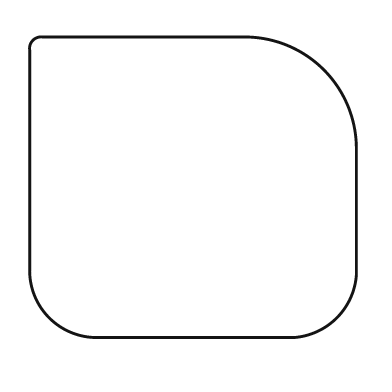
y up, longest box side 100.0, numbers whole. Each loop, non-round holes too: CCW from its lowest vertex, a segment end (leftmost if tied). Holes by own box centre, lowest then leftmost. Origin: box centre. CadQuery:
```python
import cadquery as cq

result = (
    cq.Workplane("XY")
    .moveTo(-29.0, -46.0)
    .lineTo(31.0, -46.0)
    .threePointArc((44.0, -40.0), (50.0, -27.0))
    .lineTo(50.0, 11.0)
    .threePointArc((40.0, 36.0), (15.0, 46.0))
    .lineTo(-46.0, 46.0)
    .threePointArc((-49.0, 45.0), (-50.0, 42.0))
    .lineTo(-50.0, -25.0)
    .threePointArc((-44.0, -40.0), (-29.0, -46.0))
    .close()
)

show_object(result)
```